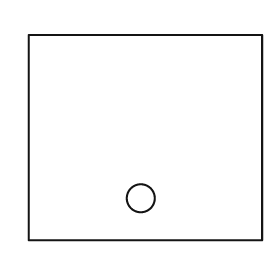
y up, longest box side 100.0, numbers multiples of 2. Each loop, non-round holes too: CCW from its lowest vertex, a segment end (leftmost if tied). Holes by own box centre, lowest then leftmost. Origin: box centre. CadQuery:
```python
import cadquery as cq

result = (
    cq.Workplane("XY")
    .moveTo(-50.0, -44.0)
    .lineTo(50.0, -44.0)
    .lineTo(50.0, 44.0)
    .lineTo(-50.0, 44.0)
    .close()
    .moveTo(-2.0, -26.0)
    .circle(6.0)
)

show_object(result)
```